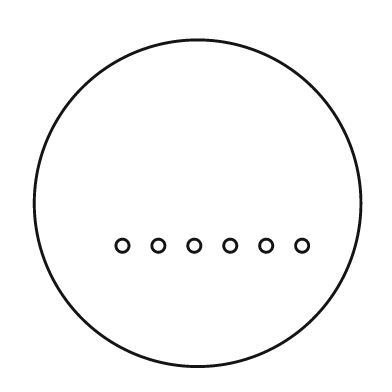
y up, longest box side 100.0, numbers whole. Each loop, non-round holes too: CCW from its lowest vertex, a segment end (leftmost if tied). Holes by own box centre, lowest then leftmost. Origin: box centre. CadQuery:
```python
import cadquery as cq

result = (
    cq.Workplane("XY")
    .moveTo(0.0, 0.0)
    .circle(50.0)
    .moveTo(-23.0, -13.0)
    .circle(2.0)
    .moveTo(-12.0, -13.0)
    .circle(2.0)
    .moveTo(-1.0, -13.0)
    .circle(2.0)
    .moveTo(10.0, -13.0)
    .circle(2.0)
    .moveTo(21.0, -13.0)
    .circle(2.0)
    .moveTo(32.0, -13.0)
    .circle(2.0)
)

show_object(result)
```